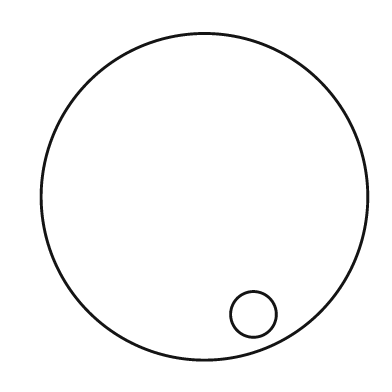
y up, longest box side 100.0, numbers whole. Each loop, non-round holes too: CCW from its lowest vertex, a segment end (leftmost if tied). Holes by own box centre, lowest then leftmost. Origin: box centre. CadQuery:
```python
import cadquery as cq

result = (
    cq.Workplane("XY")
    .moveTo(0.0, 0.0)
    .circle(50.0)
    .moveTo(15.0, -36.0)
    .circle(7.0)
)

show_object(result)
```